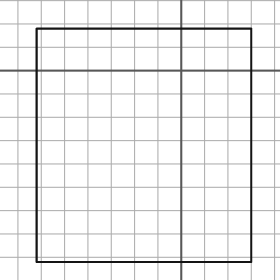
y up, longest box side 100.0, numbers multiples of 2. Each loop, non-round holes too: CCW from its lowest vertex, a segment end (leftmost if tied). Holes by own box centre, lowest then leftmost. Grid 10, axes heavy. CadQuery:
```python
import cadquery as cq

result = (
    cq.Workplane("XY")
    .moveTo(-62.0, -82.0)
    .lineTo(30.0, -82.0)
    .lineTo(30.0, 18.0)
    .lineTo(-62.0, 18.0)
    .close()
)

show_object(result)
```